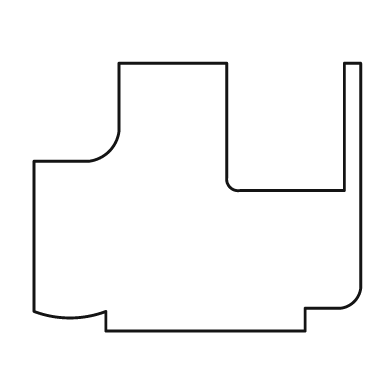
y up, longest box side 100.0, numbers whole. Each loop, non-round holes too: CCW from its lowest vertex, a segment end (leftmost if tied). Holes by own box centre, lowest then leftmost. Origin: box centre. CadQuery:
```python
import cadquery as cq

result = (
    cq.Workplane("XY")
    .moveTo(-28.0, -41.0)
    .lineTo(33.0, -41.0)
    .lineTo(33.0, -34.0)
    .lineTo(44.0, -34.0)
    .threePointArc((48.0, -32.0), (50.0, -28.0))
    .lineTo(50.0, 41.0)
    .lineTo(45.0, 41.0)
    .lineTo(45.0, 2.0)
    .lineTo(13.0, 2.0)
    .threePointArc((10.0, 3.0), (9.0, 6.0))
    .lineTo(9.0, 41.0)
    .lineTo(-24.0, 41.0)
    .lineTo(-24.0, 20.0)
    .threePointArc((-27.0, 14.0), (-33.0, 11.0))
    .lineTo(-50.0, 11.0)
    .lineTo(-50.0, -35.0)
    .threePointArc((-39.0, -37.0), (-28.0, -35.0))
    .close()
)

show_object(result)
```